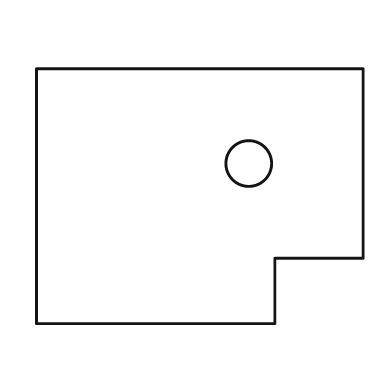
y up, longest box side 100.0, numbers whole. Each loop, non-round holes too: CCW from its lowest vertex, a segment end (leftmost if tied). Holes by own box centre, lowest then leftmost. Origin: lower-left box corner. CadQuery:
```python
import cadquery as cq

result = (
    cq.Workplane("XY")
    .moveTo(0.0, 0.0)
    .lineTo(73.0, 0.0)
    .lineTo(73.0, 20.0)
    .lineTo(100.0, 20.0)
    .lineTo(100.0, 78.0)
    .lineTo(0.0, 78.0)
    .close()
    .moveTo(65.0, 49.0)
    .circle(7.0)
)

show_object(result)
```